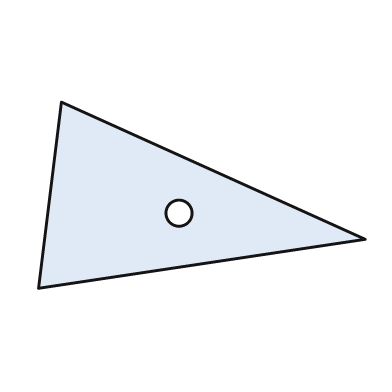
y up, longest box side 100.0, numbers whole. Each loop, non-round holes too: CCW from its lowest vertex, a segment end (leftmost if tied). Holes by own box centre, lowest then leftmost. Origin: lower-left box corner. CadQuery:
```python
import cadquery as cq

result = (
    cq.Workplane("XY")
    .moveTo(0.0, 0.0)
    .lineTo(100.0, 15.0)
    .lineTo(7.0, 57.0)
    .close()
    .moveTo(43.0, 23.0)
    .circle(4.0)
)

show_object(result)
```